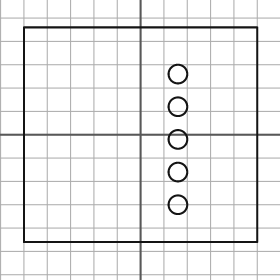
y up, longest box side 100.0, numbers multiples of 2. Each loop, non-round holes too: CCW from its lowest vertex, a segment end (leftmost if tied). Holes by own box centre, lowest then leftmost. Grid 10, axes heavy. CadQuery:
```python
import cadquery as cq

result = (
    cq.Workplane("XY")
    .moveTo(-50.0, -46.0)
    .lineTo(50.0, -46.0)
    .lineTo(50.0, 46.0)
    .lineTo(-50.0, 46.0)
    .close()
    .moveTo(16.0, -30.0)
    .circle(4.0)
    .moveTo(16.0, -16.0)
    .circle(4.0)
    .moveTo(16.0, -2.0)
    .circle(4.0)
    .moveTo(16.0, 12.0)
    .circle(4.0)
    .moveTo(16.0, 26.0)
    .circle(4.0)
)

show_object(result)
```